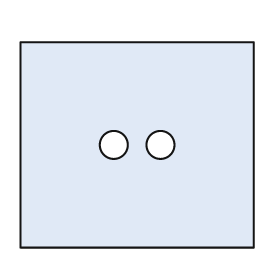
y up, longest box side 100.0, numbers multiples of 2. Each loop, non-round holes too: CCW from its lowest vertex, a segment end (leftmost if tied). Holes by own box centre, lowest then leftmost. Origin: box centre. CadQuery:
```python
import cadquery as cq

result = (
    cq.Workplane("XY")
    .moveTo(-50.0, -44.0)
    .lineTo(50.0, -44.0)
    .lineTo(50.0, 44.0)
    .lineTo(-50.0, 44.0)
    .close()
    .moveTo(-10.0, 0.0)
    .circle(6.0)
    .moveTo(10.0, 0.0)
    .circle(6.0)
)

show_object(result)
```